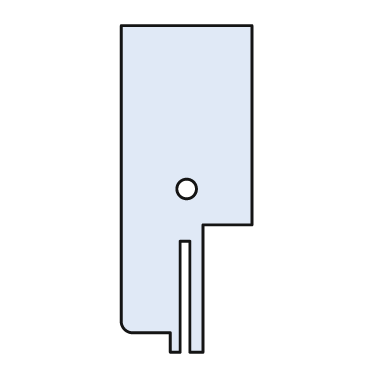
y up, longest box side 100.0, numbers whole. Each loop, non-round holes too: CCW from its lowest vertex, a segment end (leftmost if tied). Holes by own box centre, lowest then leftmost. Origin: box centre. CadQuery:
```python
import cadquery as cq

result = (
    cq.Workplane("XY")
    .moveTo(-5.0, -50.0)
    .lineTo(-2.0, -50.0)
    .lineTo(-2.0, -16.0)
    .lineTo(1.0, -16.0)
    .lineTo(1.0, -50.0)
    .lineTo(5.0, -50.0)
    .lineTo(5.0, -11.0)
    .lineTo(20.0, -11.0)
    .lineTo(20.0, 50.0)
    .lineTo(-20.0, 50.0)
    .lineTo(-20.0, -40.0)
    .threePointArc((-19.0, -43.0), (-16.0, -44.0))
    .lineTo(-5.0, -44.0)
    .close()
    .moveTo(0.0, 0.0)
    .circle(3.0)
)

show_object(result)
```